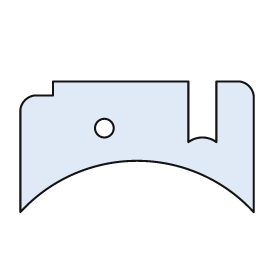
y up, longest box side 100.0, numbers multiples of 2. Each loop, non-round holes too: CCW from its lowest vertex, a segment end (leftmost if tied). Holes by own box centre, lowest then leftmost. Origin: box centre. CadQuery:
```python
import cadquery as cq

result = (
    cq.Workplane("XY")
    .moveTo(-50.0, -28.0)
    .threePointArc((0.0, -6.0), (50.0, -28.0))
    .lineTo(50.0, 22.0)
    .threePointArc((48.0, 26.0), (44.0, 28.0))
    .lineTo(34.0, 28.0)
    .lineTo(34.0, 2.0)
    .threePointArc((28.0, 4.0), (22.0, 2.0))
    .lineTo(22.0, 28.0)
    .lineTo(-36.0, 28.0)
    .lineTo(-36.0, 22.0)
    .lineTo(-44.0, 22.0)
    .threePointArc((-48.0, 20.0), (-50.0, 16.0))
    .close()
    .moveTo(-14.0, 8.0)
    .circle(4.0)
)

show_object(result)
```